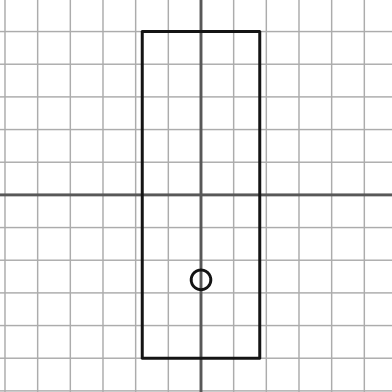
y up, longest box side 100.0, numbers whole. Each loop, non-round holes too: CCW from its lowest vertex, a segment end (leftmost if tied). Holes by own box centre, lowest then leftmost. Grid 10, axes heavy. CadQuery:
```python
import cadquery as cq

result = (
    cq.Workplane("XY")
    .moveTo(-18.0, -50.0)
    .lineTo(18.0, -50.0)
    .lineTo(18.0, 50.0)
    .lineTo(-18.0, 50.0)
    .close()
    .moveTo(0.0, -26.0)
    .circle(3.0)
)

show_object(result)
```